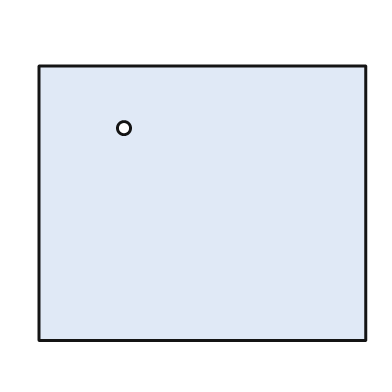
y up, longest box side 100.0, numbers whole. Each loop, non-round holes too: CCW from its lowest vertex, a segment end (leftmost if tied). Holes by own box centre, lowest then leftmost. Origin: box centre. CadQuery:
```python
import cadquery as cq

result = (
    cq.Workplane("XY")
    .moveTo(-50.0, -42.0)
    .lineTo(50.0, -42.0)
    .lineTo(50.0, 42.0)
    .lineTo(-50.0, 42.0)
    .close()
    .moveTo(-24.0, 23.0)
    .circle(2.0)
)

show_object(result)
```